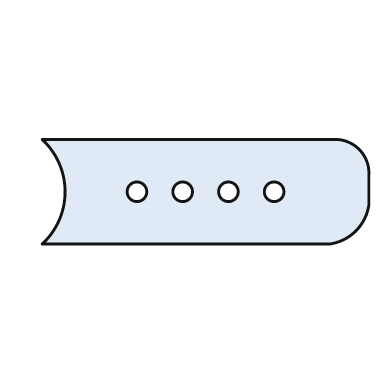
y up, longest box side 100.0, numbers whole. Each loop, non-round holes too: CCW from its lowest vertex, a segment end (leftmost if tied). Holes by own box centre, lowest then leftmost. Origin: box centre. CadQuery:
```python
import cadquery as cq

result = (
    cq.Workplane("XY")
    .moveTo(-50.0, -16.0)
    .lineTo(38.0, -16.0)
    .threePointArc((46.0, -12.0), (50.0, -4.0))
    .lineTo(50.0, 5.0)
    .threePointArc((47.0, 13.0), (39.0, 16.0))
    .lineTo(-50.0, 16.0)
    .threePointArc((-43.0, 0.0), (-50.0, -16.0))
    .close()
    .moveTo(-21.0, 0.0)
    .circle(3.0)
    .moveTo(-7.0, 0.0)
    .circle(3.0)
    .moveTo(7.0, 0.0)
    .circle(3.0)
    .moveTo(21.0, 0.0)
    .circle(3.0)
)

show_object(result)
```